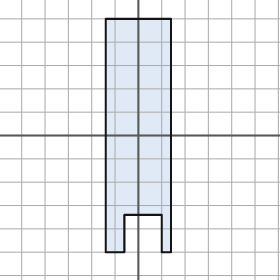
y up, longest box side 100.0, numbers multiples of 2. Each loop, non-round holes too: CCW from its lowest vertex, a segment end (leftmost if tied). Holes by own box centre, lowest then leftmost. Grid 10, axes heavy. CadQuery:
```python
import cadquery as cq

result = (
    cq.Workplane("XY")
    .moveTo(-14.0, -50.0)
    .lineTo(-6.0, -50.0)
    .lineTo(-6.0, -34.0)
    .lineTo(10.0, -34.0)
    .lineTo(10.0, -50.0)
    .lineTo(14.0, -50.0)
    .lineTo(14.0, 50.0)
    .lineTo(-14.0, 50.0)
    .close()
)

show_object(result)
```